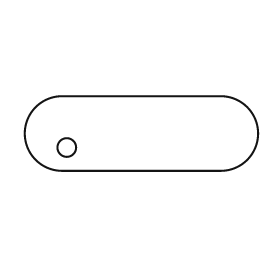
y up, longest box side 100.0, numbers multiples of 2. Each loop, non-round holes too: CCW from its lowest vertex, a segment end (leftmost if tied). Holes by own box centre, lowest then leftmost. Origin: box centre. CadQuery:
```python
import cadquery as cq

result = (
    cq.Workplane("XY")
    .moveTo(-34.0, -16.0)
    .lineTo(34.0, -16.0)
    .threePointArc((50.0, 0.0), (34.0, 16.0))
    .lineTo(-34.0, 16.0)
    .threePointArc((-50.0, 0.0), (-34.0, -16.0))
    .close()
    .moveTo(-32.0, -6.0)
    .circle(4.0)
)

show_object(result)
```